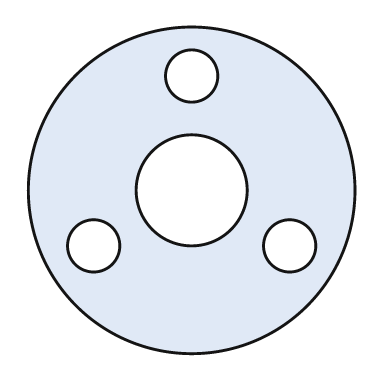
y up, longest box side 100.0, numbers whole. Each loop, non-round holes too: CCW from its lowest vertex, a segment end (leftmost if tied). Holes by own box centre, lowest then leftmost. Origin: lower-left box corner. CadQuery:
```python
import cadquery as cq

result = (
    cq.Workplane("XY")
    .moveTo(50.0, 50.0)
    .circle(50.0)
    .moveTo(20.0, 33.0)
    .circle(8.0)
    .moveTo(80.0, 33.0)
    .circle(8.0)
    .moveTo(50.0, 50.0)
    .circle(17.0)
    .moveTo(50.0, 85.0)
    .circle(8.0)
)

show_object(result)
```